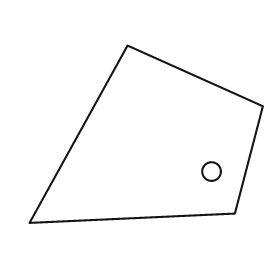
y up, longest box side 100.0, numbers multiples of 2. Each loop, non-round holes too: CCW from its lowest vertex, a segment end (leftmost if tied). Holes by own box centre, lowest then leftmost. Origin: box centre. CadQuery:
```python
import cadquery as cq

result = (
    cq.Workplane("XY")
    .moveTo(-50.0, -38.0)
    .lineTo(38.0, -34.0)
    .lineTo(50.0, 12.0)
    .lineTo(-8.0, 38.0)
    .close()
    .moveTo(28.0, -16.0)
    .circle(4.0)
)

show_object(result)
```